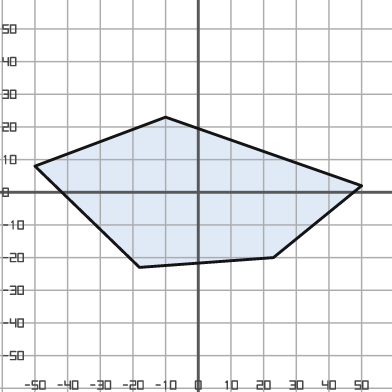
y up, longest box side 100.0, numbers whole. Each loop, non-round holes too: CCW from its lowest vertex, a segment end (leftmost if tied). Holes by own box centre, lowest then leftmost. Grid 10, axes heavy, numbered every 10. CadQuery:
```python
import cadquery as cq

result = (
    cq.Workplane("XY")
    .moveTo(-18.0, -23.0)
    .lineTo(23.0, -20.0)
    .lineTo(50.0, 2.0)
    .lineTo(-10.0, 23.0)
    .lineTo(-50.0, 8.0)
    .close()
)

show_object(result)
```